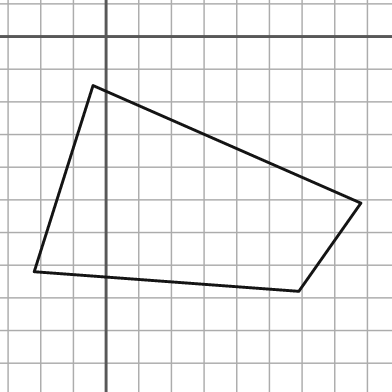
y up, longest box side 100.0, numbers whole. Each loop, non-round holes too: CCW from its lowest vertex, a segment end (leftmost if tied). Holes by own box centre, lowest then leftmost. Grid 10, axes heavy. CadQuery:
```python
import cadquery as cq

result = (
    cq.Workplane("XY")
    .moveTo(59.0, -78.0)
    .lineTo(78.0, -51.0)
    .lineTo(-4.0, -15.0)
    .lineTo(-22.0, -72.0)
    .close()
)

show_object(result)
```